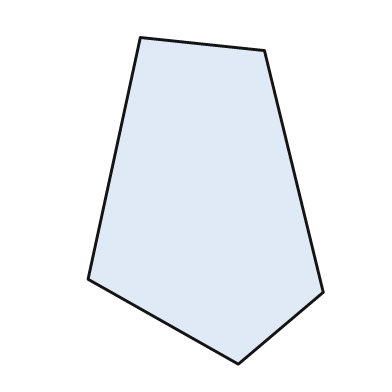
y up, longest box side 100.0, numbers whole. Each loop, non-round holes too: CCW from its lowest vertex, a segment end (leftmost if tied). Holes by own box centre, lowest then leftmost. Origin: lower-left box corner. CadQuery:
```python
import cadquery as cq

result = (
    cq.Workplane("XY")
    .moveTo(46.0, 0.0)
    .lineTo(72.0, 22.0)
    .lineTo(54.0, 96.0)
    .lineTo(16.0, 100.0)
    .lineTo(0.0, 26.0)
    .close()
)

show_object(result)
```